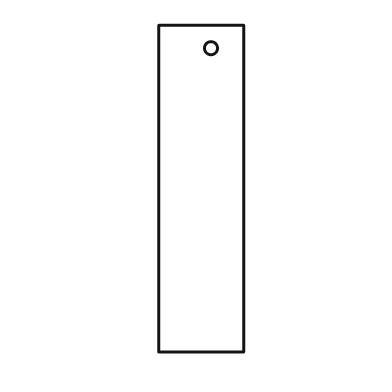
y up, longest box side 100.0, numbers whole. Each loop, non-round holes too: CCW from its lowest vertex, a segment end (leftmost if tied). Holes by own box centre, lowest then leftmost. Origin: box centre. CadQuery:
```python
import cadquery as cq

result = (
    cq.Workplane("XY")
    .moveTo(-13.0, -50.0)
    .lineTo(13.0, -50.0)
    .lineTo(13.0, 50.0)
    .lineTo(-13.0, 50.0)
    .close()
    .moveTo(3.0, 43.0)
    .circle(2.0)
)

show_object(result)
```